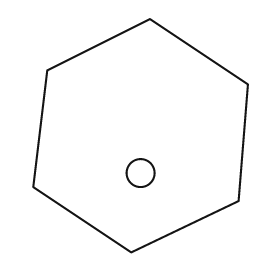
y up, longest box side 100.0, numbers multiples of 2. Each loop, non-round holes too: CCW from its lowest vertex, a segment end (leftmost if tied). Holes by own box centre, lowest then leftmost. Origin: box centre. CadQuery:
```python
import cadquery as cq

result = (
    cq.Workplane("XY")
    .moveTo(-4.0, -50.0)
    .lineTo(42.0, -28.0)
    .lineTo(46.0, 22.0)
    .lineTo(4.0, 50.0)
    .lineTo(-40.0, 28.0)
    .lineTo(-46.0, -22.0)
    .close()
    .moveTo(0.0, -16.0)
    .circle(6.0)
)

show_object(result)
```